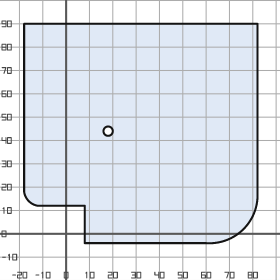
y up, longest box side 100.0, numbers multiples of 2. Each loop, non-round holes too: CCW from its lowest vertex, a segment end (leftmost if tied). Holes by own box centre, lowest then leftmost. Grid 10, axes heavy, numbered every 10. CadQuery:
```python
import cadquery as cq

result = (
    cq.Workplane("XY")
    .moveTo(8.0, -4.0)
    .lineTo(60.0, -4.0)
    .threePointArc((76.0, 2.0), (82.0, 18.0))
    .lineTo(82.0, 90.0)
    .lineTo(-18.0, 90.0)
    .lineTo(-18.0, 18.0)
    .threePointArc((-16.0, 14.0), (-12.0, 12.0))
    .lineTo(8.0, 12.0)
    .close()
    .moveTo(18.0, 44.0)
    .circle(2.0)
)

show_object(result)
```